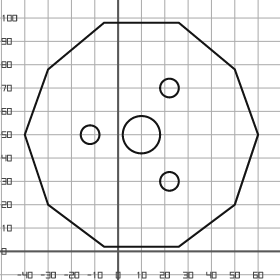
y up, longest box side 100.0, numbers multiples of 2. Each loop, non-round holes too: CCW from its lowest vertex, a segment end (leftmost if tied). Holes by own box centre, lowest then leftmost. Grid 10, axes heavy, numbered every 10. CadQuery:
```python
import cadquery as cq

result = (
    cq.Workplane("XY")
    .moveTo(-6.0, 2.0)
    .lineTo(26.0, 2.0)
    .lineTo(50.0, 20.0)
    .lineTo(60.0, 50.0)
    .lineTo(50.0, 78.0)
    .lineTo(26.0, 98.0)
    .lineTo(-6.0, 98.0)
    .lineTo(-30.0, 78.0)
    .lineTo(-40.0, 50.0)
    .lineTo(-30.0, 20.0)
    .close()
    .moveTo(22.0, 30.0)
    .circle(4.0)
    .moveTo(-12.0, 50.0)
    .circle(4.0)
    .moveTo(10.0, 50.0)
    .circle(8.0)
    .moveTo(22.0, 70.0)
    .circle(4.0)
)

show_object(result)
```